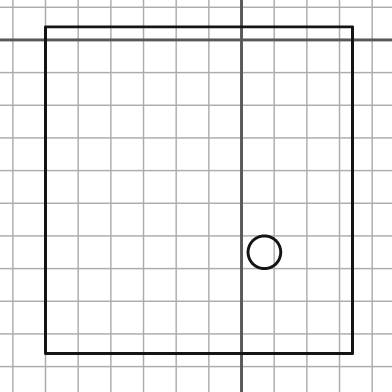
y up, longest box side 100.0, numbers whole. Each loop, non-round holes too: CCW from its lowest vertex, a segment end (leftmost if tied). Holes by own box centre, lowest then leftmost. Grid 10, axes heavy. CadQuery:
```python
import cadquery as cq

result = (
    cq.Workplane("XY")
    .moveTo(-60.0, -96.0)
    .lineTo(34.0, -96.0)
    .lineTo(34.0, 4.0)
    .lineTo(-60.0, 4.0)
    .close()
    .moveTo(7.0, -65.0)
    .circle(5.0)
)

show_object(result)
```